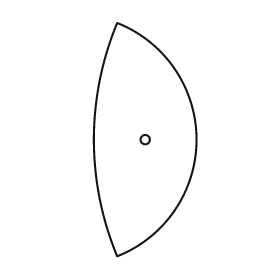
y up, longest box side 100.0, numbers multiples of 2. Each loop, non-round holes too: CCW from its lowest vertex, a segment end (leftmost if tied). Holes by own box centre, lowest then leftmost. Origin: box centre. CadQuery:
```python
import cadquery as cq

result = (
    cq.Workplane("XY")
    .moveTo(-12.0, -50.0)
    .threePointArc((22.0, 0.0), (-12.0, 50.0))
    .threePointArc((-22.0, 0.0), (-12.0, -50.0))
    .close()
    .moveTo(0.0, 0.0)
    .circle(2.0)
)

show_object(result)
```